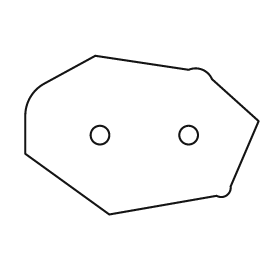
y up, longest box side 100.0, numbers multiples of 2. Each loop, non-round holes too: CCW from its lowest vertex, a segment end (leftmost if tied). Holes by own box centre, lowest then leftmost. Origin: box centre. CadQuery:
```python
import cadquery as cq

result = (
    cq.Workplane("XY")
    .moveTo(-14.0, -34.0)
    .lineTo(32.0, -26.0)
    .threePointArc((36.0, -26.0), (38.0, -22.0))
    .lineTo(50.0, 6.0)
    .lineTo(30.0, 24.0)
    .threePointArc((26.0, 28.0), (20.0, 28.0))
    .lineTo(-20.0, 34.0)
    .lineTo(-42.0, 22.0)
    .threePointArc((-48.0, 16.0), (-50.0, 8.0))
    .lineTo(-50.0, -8.0)
    .close()
    .moveTo(-18.0, 0.0)
    .circle(4.0)
    .moveTo(20.0, 0.0)
    .circle(4.0)
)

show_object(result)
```